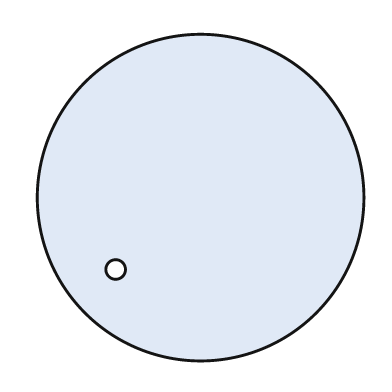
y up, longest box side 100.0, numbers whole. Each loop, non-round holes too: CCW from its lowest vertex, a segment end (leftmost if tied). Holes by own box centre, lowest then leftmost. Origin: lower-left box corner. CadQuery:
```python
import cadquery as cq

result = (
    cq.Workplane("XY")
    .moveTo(50.0, 50.0)
    .circle(50.0)
    .moveTo(24.0, 28.0)
    .circle(3.0)
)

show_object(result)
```